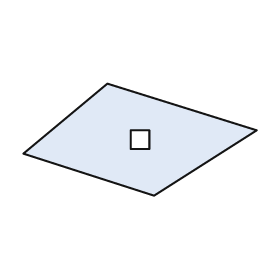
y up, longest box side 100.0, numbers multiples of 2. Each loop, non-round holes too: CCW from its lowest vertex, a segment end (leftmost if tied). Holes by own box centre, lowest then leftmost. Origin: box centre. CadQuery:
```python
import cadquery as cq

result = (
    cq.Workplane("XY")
    .moveTo(6.0, -24.0)
    .lineTo(50.0, 4.0)
    .lineTo(-14.0, 24.0)
    .lineTo(-50.0, -6.0)
    .close()
    .moveTo(-4.0, -4.0)
    .lineTo(4.0, -4.0)
    .lineTo(4.0, 4.0)
    .lineTo(-4.0, 4.0)
    .close()
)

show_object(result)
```